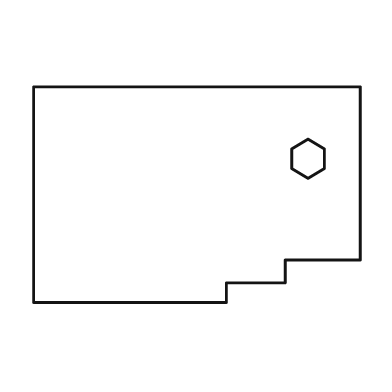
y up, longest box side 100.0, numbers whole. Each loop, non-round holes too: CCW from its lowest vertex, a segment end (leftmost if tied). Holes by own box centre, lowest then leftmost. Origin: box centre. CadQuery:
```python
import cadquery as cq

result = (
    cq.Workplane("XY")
    .moveTo(-50.0, -33.0)
    .lineTo(9.0, -33.0)
    .lineTo(9.0, -27.0)
    .lineTo(27.0, -27.0)
    .lineTo(27.0, -20.0)
    .lineTo(50.0, -20.0)
    .lineTo(50.0, 33.0)
    .lineTo(-50.0, 33.0)
    .close()
    .moveTo(34.0, 5.0)
    .lineTo(39.0, 8.0)
    .lineTo(39.0, 14.0)
    .lineTo(34.0, 17.0)
    .lineTo(29.0, 14.0)
    .lineTo(29.0, 8.0)
    .close()
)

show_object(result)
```